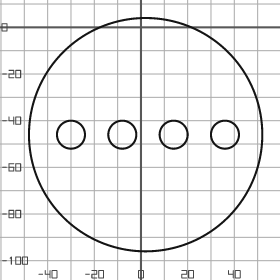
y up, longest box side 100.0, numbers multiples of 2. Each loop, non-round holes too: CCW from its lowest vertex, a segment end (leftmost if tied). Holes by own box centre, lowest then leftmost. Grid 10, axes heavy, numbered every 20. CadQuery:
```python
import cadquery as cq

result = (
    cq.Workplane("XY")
    .moveTo(2.0, -46.0)
    .circle(50.0)
    .moveTo(-30.0, -46.0)
    .circle(6.0)
    .moveTo(-8.0, -46.0)
    .circle(6.0)
    .moveTo(14.0, -46.0)
    .circle(6.0)
    .moveTo(36.0, -46.0)
    .circle(6.0)
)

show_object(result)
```